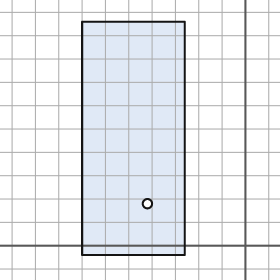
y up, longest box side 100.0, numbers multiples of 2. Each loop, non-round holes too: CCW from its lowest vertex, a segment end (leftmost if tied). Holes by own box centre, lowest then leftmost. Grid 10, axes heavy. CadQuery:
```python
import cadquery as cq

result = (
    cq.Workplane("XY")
    .moveTo(-70.0, -4.0)
    .lineTo(-26.0, -4.0)
    .lineTo(-26.0, 96.0)
    .lineTo(-70.0, 96.0)
    .close()
    .moveTo(-42.0, 18.0)
    .circle(2.0)
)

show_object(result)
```